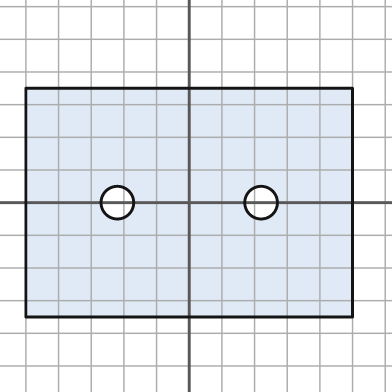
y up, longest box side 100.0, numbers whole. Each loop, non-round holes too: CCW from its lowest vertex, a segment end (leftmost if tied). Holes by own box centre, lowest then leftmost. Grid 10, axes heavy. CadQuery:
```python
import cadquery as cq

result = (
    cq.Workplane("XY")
    .moveTo(-50.0, -35.0)
    .lineTo(50.0, -35.0)
    .lineTo(50.0, 35.0)
    .lineTo(-50.0, 35.0)
    .close()
    .moveTo(-22.0, 0.0)
    .circle(5.0)
    .moveTo(22.0, 0.0)
    .circle(5.0)
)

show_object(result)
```